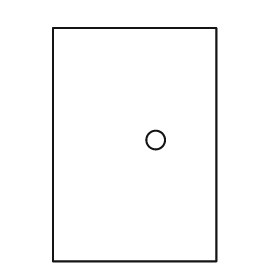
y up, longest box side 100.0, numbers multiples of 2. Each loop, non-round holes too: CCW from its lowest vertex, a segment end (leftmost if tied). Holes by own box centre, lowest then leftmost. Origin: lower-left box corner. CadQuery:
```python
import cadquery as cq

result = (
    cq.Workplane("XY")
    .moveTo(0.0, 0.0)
    .lineTo(70.0, 0.0)
    .lineTo(70.0, 100.0)
    .lineTo(0.0, 100.0)
    .close()
    .moveTo(44.0, 52.0)
    .circle(4.0)
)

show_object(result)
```